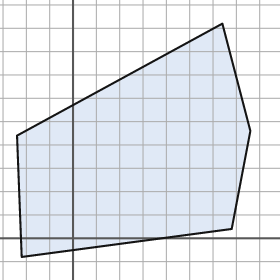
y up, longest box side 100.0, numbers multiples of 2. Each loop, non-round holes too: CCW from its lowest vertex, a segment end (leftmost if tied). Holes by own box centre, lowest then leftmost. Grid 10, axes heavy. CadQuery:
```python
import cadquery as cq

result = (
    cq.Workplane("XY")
    .moveTo(-22.0, -8.0)
    .lineTo(68.0, 4.0)
    .lineTo(76.0, 46.0)
    .lineTo(64.0, 92.0)
    .lineTo(-24.0, 44.0)
    .close()
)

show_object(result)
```